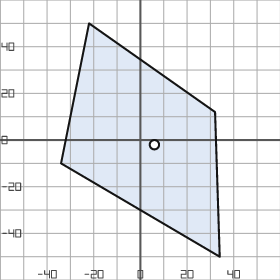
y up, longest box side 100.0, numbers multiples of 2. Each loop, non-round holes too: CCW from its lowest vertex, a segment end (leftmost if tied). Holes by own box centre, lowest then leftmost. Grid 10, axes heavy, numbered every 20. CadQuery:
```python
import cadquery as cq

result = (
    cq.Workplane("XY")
    .moveTo(34.0, -50.0)
    .lineTo(32.0, 12.0)
    .lineTo(-22.0, 50.0)
    .lineTo(-34.0, -10.0)
    .close()
    .moveTo(6.0, -2.0)
    .circle(2.0)
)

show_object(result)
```